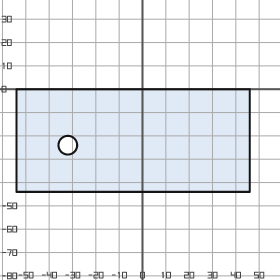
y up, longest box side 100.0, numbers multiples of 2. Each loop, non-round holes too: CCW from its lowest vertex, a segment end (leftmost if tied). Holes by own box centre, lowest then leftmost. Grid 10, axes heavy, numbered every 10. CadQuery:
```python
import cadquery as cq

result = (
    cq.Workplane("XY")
    .moveTo(-54.0, -44.0)
    .lineTo(46.0, -44.0)
    .lineTo(46.0, 0.0)
    .lineTo(-54.0, 0.0)
    .close()
    .moveTo(-32.0, -24.0)
    .circle(4.0)
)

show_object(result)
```